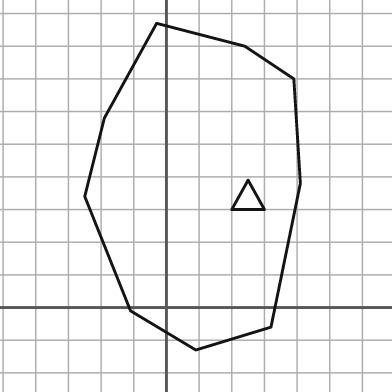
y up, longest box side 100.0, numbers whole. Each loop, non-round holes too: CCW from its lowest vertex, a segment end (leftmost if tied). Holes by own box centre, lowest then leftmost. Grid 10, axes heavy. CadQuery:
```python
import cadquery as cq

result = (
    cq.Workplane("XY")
    .moveTo(9.0, -13.0)
    .lineTo(32.0, -6.0)
    .lineTo(41.0, 38.0)
    .lineTo(39.0, 70.0)
    .lineTo(24.0, 80.0)
    .lineTo(-3.0, 87.0)
    .lineTo(-19.0, 58.0)
    .lineTo(-25.0, 34.0)
    .lineTo(-11.0, -1.0)
    .close()
    .moveTo(20.0, 30.0)
    .lineTo(30.0, 30.0)
    .lineTo(25.0, 39.0)
    .close()
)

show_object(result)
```